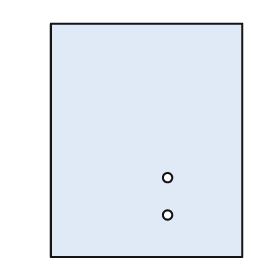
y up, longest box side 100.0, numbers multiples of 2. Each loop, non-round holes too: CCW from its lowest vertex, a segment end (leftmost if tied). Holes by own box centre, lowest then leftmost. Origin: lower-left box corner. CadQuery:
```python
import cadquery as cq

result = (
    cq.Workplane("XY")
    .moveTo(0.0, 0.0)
    .lineTo(82.0, 0.0)
    .lineTo(82.0, 100.0)
    .lineTo(0.0, 100.0)
    .close()
    .moveTo(50.0, 18.0)
    .circle(2.0)
    .moveTo(50.0, 34.0)
    .circle(2.0)
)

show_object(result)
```